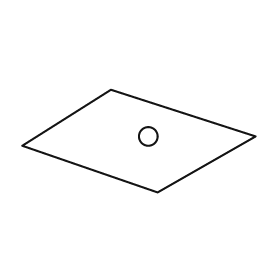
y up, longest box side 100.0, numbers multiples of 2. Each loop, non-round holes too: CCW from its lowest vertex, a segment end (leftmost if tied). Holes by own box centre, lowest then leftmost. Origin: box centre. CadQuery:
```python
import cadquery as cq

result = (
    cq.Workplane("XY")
    .moveTo(8.0, -22.0)
    .lineTo(50.0, 2.0)
    .lineTo(-12.0, 22.0)
    .lineTo(-50.0, -2.0)
    .close()
    .moveTo(4.0, 2.0)
    .circle(4.0)
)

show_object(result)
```